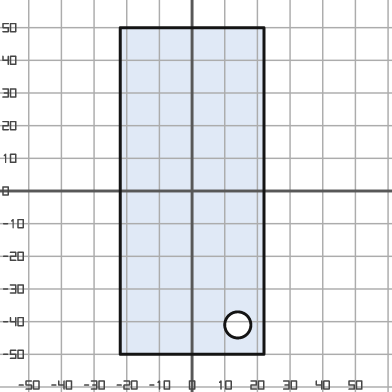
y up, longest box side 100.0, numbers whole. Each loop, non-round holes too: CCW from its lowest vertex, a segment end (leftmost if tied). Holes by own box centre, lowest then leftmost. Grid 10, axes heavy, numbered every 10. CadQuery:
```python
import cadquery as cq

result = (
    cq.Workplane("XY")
    .moveTo(-22.0, -50.0)
    .lineTo(22.0, -50.0)
    .lineTo(22.0, 50.0)
    .lineTo(-22.0, 50.0)
    .close()
    .moveTo(14.0, -41.0)
    .circle(4.0)
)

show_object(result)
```